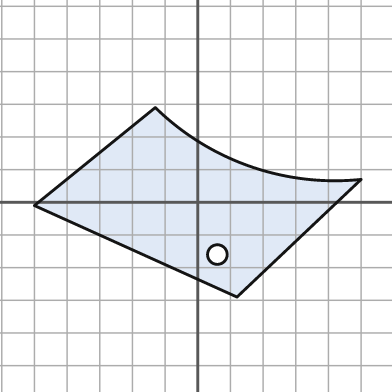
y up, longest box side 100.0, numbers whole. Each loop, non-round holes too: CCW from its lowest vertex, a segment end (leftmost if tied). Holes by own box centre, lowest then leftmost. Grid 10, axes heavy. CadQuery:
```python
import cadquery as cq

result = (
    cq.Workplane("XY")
    .moveTo(12.0, -29.0)
    .lineTo(50.0, 7.0)
    .threePointArc((16.0, 11.0), (-13.0, 29.0))
    .lineTo(-50.0, -1.0)
    .close()
    .moveTo(6.0, -16.0)
    .circle(3.0)
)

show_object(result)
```